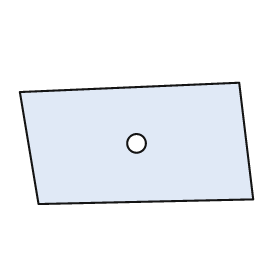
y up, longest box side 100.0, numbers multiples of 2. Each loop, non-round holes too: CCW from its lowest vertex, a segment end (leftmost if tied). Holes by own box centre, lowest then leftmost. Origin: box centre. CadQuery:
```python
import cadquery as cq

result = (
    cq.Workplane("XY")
    .moveTo(-42.0, -26.0)
    .lineTo(50.0, -24.0)
    .lineTo(44.0, 26.0)
    .lineTo(-50.0, 22.0)
    .close()
    .moveTo(0.0, 0.0)
    .circle(4.0)
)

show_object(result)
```